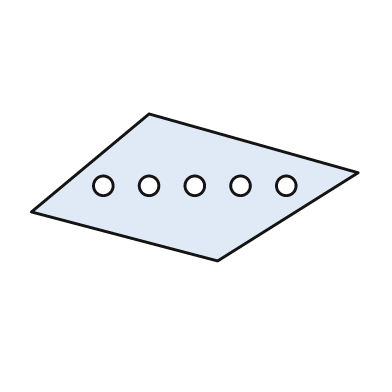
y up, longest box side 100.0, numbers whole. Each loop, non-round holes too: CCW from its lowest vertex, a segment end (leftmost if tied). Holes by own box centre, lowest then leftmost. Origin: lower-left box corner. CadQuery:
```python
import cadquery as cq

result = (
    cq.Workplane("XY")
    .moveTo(57.0, 0.0)
    .lineTo(100.0, 27.0)
    .lineTo(36.0, 45.0)
    .lineTo(0.0, 15.0)
    .close()
    .moveTo(22.0, 23.0)
    .circle(3.0)
    .moveTo(36.0, 23.0)
    .circle(3.0)
    .moveTo(50.0, 23.0)
    .circle(3.0)
    .moveTo(64.0, 23.0)
    .circle(3.0)
    .moveTo(78.0, 23.0)
    .circle(3.0)
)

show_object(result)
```